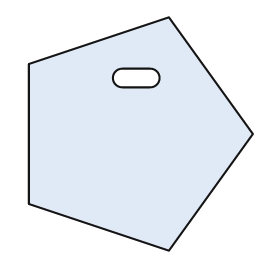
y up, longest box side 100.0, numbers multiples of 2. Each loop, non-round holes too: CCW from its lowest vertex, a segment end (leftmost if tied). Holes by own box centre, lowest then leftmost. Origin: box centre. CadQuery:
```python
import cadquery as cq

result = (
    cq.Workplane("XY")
    .moveTo(12.0, -50.0)
    .lineTo(48.0, 0.0)
    .lineTo(12.0, 50.0)
    .lineTo(-48.0, 30.0)
    .lineTo(-48.0, -30.0)
    .close()
    .moveTo(-8.0, 20.0)
    .lineTo(4.0, 20.0)
    .threePointArc((8.0, 24.0), (4.0, 28.0))
    .lineTo(-8.0, 28.0)
    .threePointArc((-12.0, 24.0), (-8.0, 20.0))
    .close()
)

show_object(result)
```